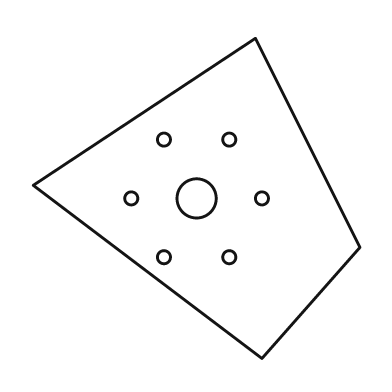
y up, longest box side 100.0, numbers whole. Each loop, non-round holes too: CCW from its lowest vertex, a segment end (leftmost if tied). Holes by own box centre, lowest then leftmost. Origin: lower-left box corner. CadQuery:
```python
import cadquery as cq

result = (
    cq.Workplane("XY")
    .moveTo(70.0, 0.0)
    .lineTo(100.0, 34.0)
    .lineTo(68.0, 98.0)
    .lineTo(0.0, 53.0)
    .close()
    .moveTo(40.0, 31.0)
    .circle(2.0)
    .moveTo(60.0, 31.0)
    .circle(2.0)
    .moveTo(30.0, 49.0)
    .circle(2.0)
    .moveTo(50.0, 49.0)
    .circle(6.0)
    .moveTo(70.0, 49.0)
    .circle(2.0)
    .moveTo(40.0, 67.0)
    .circle(2.0)
    .moveTo(60.0, 67.0)
    .circle(2.0)
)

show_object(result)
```